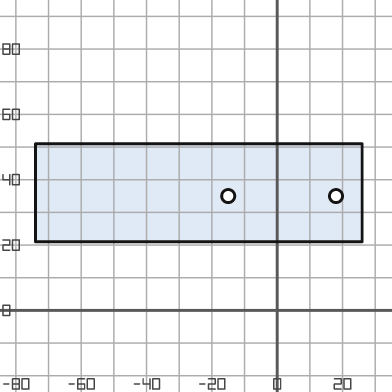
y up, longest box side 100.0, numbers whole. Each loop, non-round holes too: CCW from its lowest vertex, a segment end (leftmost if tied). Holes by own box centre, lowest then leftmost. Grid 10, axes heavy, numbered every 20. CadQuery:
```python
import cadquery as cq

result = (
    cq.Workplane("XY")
    .moveTo(-74.0, 21.0)
    .lineTo(26.0, 21.0)
    .lineTo(26.0, 51.0)
    .lineTo(-74.0, 51.0)
    .close()
    .moveTo(-15.0, 35.0)
    .circle(2.0)
    .moveTo(18.0, 35.0)
    .circle(2.0)
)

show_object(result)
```